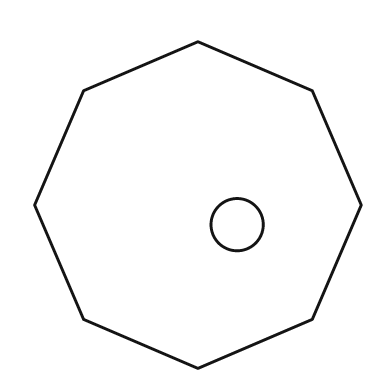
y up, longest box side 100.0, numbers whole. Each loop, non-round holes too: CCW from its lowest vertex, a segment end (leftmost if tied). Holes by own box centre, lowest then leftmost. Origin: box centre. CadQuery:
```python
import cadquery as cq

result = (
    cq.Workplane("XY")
    .moveTo(0.0, -50.0)
    .lineTo(35.0, -35.0)
    .lineTo(50.0, 0.0)
    .lineTo(35.0, 35.0)
    .lineTo(0.0, 50.0)
    .lineTo(-35.0, 35.0)
    .lineTo(-50.0, 0.0)
    .lineTo(-35.0, -35.0)
    .close()
    .moveTo(12.0, -6.0)
    .circle(8.0)
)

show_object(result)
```